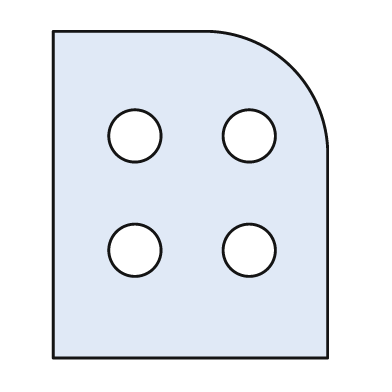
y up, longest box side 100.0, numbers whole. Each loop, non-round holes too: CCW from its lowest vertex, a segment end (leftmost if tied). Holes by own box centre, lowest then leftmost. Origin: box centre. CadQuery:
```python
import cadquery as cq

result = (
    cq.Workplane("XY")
    .moveTo(-42.0, -50.0)
    .lineTo(42.0, -50.0)
    .lineTo(42.0, 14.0)
    .threePointArc((31.0, 39.0), (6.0, 50.0))
    .lineTo(-42.0, 50.0)
    .close()
    .moveTo(-17.0, -17.0)
    .circle(8.0)
    .moveTo(18.0, -17.0)
    .circle(8.0)
    .moveTo(-17.0, 18.0)
    .circle(8.0)
    .moveTo(18.0, 18.0)
    .circle(8.0)
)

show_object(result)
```